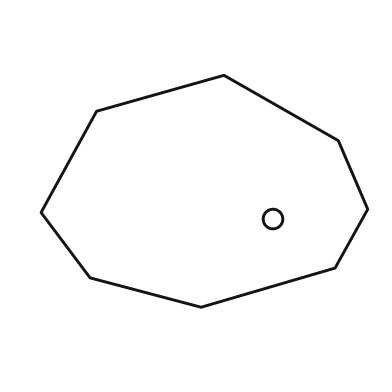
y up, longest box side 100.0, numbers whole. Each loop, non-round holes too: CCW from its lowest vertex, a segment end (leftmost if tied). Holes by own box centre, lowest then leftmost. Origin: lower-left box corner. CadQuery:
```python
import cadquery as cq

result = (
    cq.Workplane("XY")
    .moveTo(49.0, 0.0)
    .lineTo(90.0, 12.0)
    .lineTo(100.0, 30.0)
    .lineTo(91.0, 51.0)
    .lineTo(56.0, 71.0)
    .lineTo(17.0, 60.0)
    .lineTo(0.0, 29.0)
    .lineTo(15.0, 9.0)
    .close()
    .moveTo(71.0, 27.0)
    .circle(3.0)
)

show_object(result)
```